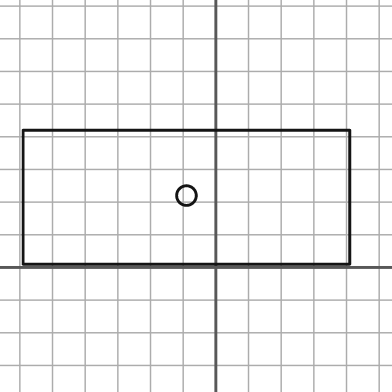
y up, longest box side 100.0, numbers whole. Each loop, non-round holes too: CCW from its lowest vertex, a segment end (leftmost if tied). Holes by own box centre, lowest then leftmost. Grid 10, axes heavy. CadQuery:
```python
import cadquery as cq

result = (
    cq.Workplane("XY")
    .moveTo(-59.0, 1.0)
    .lineTo(41.0, 1.0)
    .lineTo(41.0, 42.0)
    .lineTo(-59.0, 42.0)
    .close()
    .moveTo(-9.0, 22.0)
    .circle(3.0)
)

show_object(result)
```